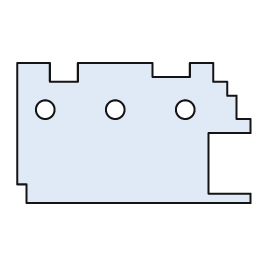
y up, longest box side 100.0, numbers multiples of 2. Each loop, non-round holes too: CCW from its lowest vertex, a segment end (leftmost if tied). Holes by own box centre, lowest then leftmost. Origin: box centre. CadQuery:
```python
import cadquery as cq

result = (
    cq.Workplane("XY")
    .moveTo(-46.0, -30.0)
    .lineTo(50.0, -30.0)
    .lineTo(50.0, -26.0)
    .lineTo(32.0, -26.0)
    .lineTo(32.0, 0.0)
    .lineTo(50.0, 0.0)
    .lineTo(50.0, 6.0)
    .lineTo(44.0, 6.0)
    .lineTo(44.0, 16.0)
    .lineTo(40.0, 16.0)
    .lineTo(40.0, 22.0)
    .lineTo(34.0, 22.0)
    .lineTo(34.0, 30.0)
    .lineTo(24.0, 30.0)
    .lineTo(24.0, 24.0)
    .lineTo(8.0, 24.0)
    .lineTo(8.0, 30.0)
    .lineTo(-24.0, 30.0)
    .lineTo(-24.0, 22.0)
    .lineTo(-36.0, 22.0)
    .lineTo(-36.0, 30.0)
    .lineTo(-50.0, 30.0)
    .lineTo(-50.0, -22.0)
    .lineTo(-46.0, -22.0)
    .close()
    .moveTo(-38.0, 10.0)
    .circle(4.0)
    .moveTo(-8.0, 10.0)
    .circle(4.0)
    .moveTo(22.0, 10.0)
    .circle(4.0)
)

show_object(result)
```